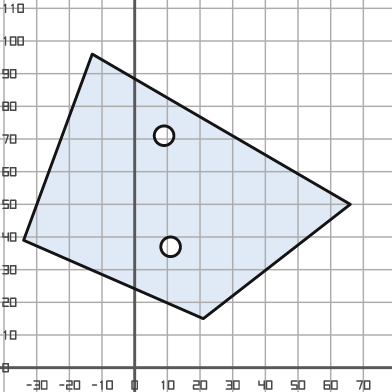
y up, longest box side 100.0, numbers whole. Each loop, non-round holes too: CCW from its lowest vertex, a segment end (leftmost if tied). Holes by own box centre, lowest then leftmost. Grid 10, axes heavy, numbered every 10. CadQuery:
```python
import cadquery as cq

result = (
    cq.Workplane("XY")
    .moveTo(21.0, 15.0)
    .lineTo(66.0, 50.0)
    .lineTo(-13.0, 96.0)
    .lineTo(-34.0, 39.0)
    .close()
    .moveTo(11.0, 37.0)
    .circle(3.0)
    .moveTo(9.0, 71.0)
    .circle(3.0)
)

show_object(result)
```